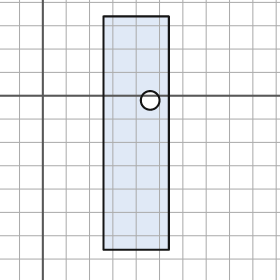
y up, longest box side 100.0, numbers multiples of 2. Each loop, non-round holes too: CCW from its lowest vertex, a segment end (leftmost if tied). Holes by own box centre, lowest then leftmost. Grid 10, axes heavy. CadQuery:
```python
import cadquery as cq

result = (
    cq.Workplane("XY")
    .moveTo(26.0, -66.0)
    .lineTo(54.0, -66.0)
    .lineTo(54.0, 34.0)
    .lineTo(26.0, 34.0)
    .close()
    .moveTo(46.0, -2.0)
    .circle(4.0)
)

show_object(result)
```